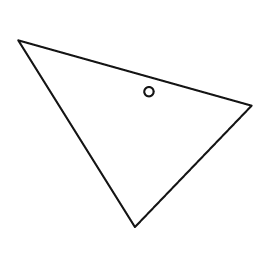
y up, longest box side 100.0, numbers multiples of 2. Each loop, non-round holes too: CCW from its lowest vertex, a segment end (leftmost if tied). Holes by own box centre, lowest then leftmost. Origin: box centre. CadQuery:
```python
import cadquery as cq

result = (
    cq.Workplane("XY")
    .moveTo(0.0, -40.0)
    .lineTo(50.0, 12.0)
    .lineTo(-50.0, 40.0)
    .close()
    .moveTo(6.0, 18.0)
    .circle(2.0)
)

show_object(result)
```